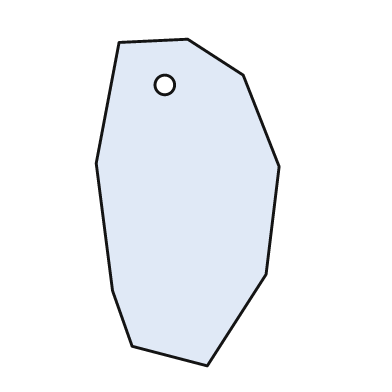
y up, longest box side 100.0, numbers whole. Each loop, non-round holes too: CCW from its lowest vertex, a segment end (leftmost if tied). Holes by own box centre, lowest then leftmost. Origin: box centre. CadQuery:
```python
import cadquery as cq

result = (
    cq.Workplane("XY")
    .moveTo(6.0, -50.0)
    .lineTo(24.0, -22.0)
    .lineTo(28.0, 11.0)
    .lineTo(17.0, 39.0)
    .lineTo(0.0, 50.0)
    .lineTo(-21.0, 49.0)
    .lineTo(-28.0, 12.0)
    .lineTo(-23.0, -27.0)
    .lineTo(-17.0, -44.0)
    .close()
    .moveTo(-7.0, 36.0)
    .circle(3.0)
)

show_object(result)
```